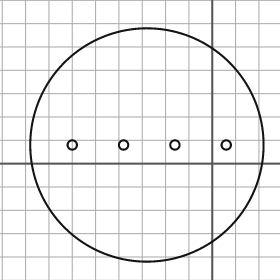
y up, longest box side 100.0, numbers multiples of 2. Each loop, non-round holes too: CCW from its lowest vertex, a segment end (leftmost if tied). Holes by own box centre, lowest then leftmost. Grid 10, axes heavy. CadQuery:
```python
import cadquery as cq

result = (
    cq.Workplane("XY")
    .moveTo(-28.0, 8.0)
    .circle(50.0)
    .moveTo(-60.0, 8.0)
    .circle(2.0)
    .moveTo(-38.0, 8.0)
    .circle(2.0)
    .moveTo(-16.0, 8.0)
    .circle(2.0)
    .moveTo(6.0, 8.0)
    .circle(2.0)
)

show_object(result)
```